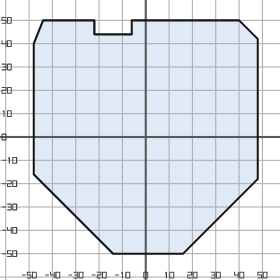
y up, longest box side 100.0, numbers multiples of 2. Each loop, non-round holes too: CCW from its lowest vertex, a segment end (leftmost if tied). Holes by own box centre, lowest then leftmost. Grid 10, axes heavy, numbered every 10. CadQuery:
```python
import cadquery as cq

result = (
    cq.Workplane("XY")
    .moveTo(-14.0, -50.0)
    .lineTo(16.0, -50.0)
    .lineTo(48.0, -18.0)
    .lineTo(48.0, 42.0)
    .lineTo(40.0, 50.0)
    .lineTo(-6.0, 50.0)
    .lineTo(-6.0, 44.0)
    .lineTo(-22.0, 44.0)
    .lineTo(-22.0, 50.0)
    .lineTo(-44.0, 50.0)
    .lineTo(-48.0, 40.0)
    .lineTo(-48.0, -16.0)
    .close()
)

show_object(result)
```